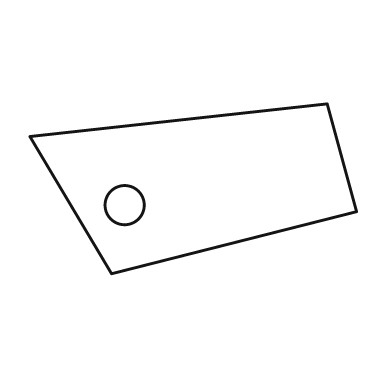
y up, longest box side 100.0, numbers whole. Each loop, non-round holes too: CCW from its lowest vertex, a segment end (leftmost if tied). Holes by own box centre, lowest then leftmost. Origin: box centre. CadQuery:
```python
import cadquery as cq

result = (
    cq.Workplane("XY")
    .moveTo(-25.0, -26.0)
    .lineTo(50.0, -7.0)
    .lineTo(41.0, 26.0)
    .lineTo(-50.0, 16.0)
    .close()
    .moveTo(-21.0, -5.0)
    .circle(6.0)
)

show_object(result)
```